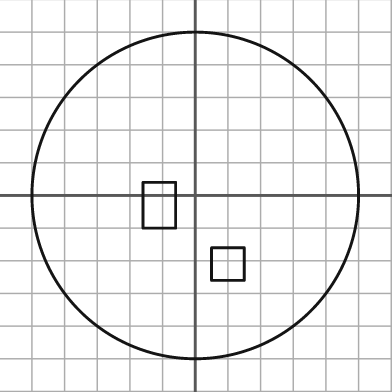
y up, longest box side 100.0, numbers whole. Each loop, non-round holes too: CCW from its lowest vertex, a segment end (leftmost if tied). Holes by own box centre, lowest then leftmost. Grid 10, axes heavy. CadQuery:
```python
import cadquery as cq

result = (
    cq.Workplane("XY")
    .moveTo(0.0, 0.0)
    .circle(50.0)
    .moveTo(5.0, -26.0)
    .lineTo(15.0, -26.0)
    .lineTo(15.0, -16.0)
    .lineTo(5.0, -16.0)
    .close()
    .moveTo(-16.0, -10.0)
    .lineTo(-6.0, -10.0)
    .lineTo(-6.0, 4.0)
    .lineTo(-16.0, 4.0)
    .close()
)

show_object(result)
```